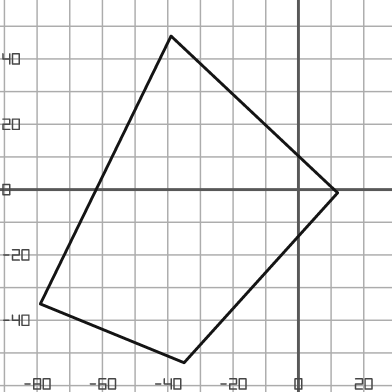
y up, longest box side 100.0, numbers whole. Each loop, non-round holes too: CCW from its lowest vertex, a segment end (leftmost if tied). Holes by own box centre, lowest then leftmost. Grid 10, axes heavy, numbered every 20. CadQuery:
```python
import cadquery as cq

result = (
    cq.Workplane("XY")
    .moveTo(-35.0, -53.0)
    .lineTo(12.0, -1.0)
    .lineTo(-39.0, 47.0)
    .lineTo(-79.0, -35.0)
    .close()
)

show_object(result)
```